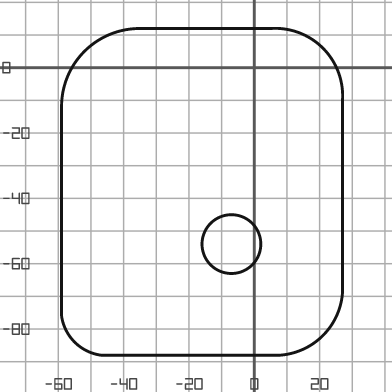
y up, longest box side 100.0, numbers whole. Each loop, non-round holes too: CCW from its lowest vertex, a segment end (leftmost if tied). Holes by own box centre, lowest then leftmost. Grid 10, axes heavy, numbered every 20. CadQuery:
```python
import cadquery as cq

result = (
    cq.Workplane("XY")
    .moveTo(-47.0, -88.0)
    .lineTo(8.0, -88.0)
    .threePointArc((21.0, -82.0), (27.0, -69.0))
    .lineTo(27.0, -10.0)
    .threePointArc((21.0, 6.0), (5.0, 12.0))
    .lineTo(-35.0, 12.0)
    .threePointArc((-52.0, 5.0), (-59.0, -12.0))
    .lineTo(-59.0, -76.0)
    .threePointArc((-55.0, -84.0), (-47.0, -88.0))
    .close()
    .moveTo(-7.0, -54.0)
    .circle(9.0)
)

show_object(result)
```